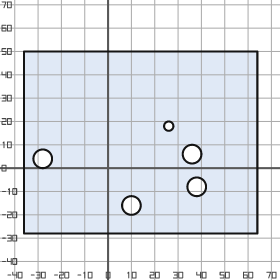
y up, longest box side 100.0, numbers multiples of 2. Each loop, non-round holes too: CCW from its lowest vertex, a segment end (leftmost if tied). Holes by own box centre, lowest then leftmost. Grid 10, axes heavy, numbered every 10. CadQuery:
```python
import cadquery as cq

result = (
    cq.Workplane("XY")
    .moveTo(-36.0, -28.0)
    .lineTo(64.0, -28.0)
    .lineTo(64.0, 50.0)
    .lineTo(-36.0, 50.0)
    .close()
    .moveTo(10.0, -16.0)
    .circle(4.0)
    .moveTo(38.0, -8.0)
    .circle(4.0)
    .moveTo(-28.0, 4.0)
    .circle(4.0)
    .moveTo(36.0, 6.0)
    .circle(4.0)
    .moveTo(26.0, 18.0)
    .circle(2.0)
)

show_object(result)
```